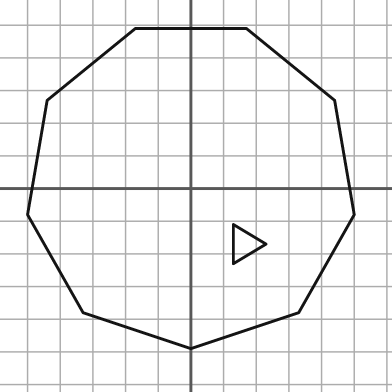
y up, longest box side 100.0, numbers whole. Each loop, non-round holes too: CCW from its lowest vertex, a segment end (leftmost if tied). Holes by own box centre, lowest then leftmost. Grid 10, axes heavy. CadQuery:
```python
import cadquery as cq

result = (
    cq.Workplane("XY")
    .moveTo(0.0, -49.0)
    .lineTo(33.0, -38.0)
    .lineTo(50.0, -8.0)
    .lineTo(44.0, 27.0)
    .lineTo(17.0, 49.0)
    .lineTo(-17.0, 49.0)
    .lineTo(-44.0, 27.0)
    .lineTo(-50.0, -8.0)
    .lineTo(-33.0, -38.0)
    .close()
    .moveTo(13.0, -23.0)
    .lineTo(23.0, -17.0)
    .lineTo(13.0, -11.0)
    .close()
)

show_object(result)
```